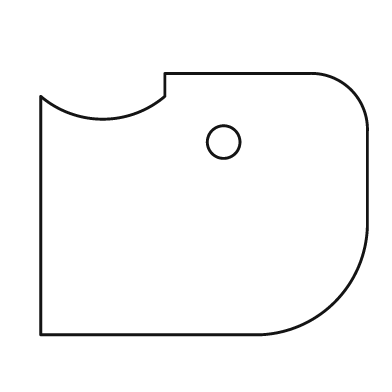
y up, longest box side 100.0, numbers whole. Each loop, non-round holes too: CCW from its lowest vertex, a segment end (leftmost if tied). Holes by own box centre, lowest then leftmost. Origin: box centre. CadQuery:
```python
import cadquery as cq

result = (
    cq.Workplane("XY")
    .moveTo(-50.0, -40.0)
    .lineTo(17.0, -40.0)
    .threePointArc((40.0, -30.0), (50.0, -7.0))
    .lineTo(50.0, 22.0)
    .threePointArc((45.0, 35.0), (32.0, 40.0))
    .lineTo(-12.0, 40.0)
    .lineTo(-12.0, 33.0)
    .threePointArc((-31.0, 26.0), (-50.0, 33.0))
    .close()
    .moveTo(6.0, 19.0)
    .circle(5.0)
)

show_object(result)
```